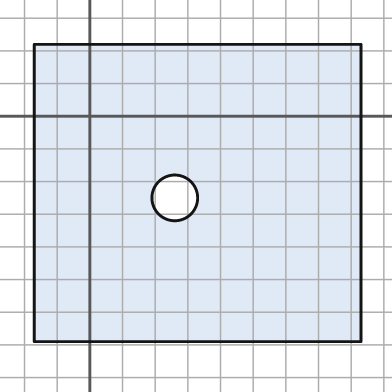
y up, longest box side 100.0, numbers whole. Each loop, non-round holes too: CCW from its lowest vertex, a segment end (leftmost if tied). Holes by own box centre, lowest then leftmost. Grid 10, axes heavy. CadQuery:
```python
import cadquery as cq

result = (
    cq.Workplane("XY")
    .moveTo(-17.0, -69.0)
    .lineTo(83.0, -69.0)
    .lineTo(83.0, 22.0)
    .lineTo(-17.0, 22.0)
    .close()
    .moveTo(26.0, -25.0)
    .circle(7.0)
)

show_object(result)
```